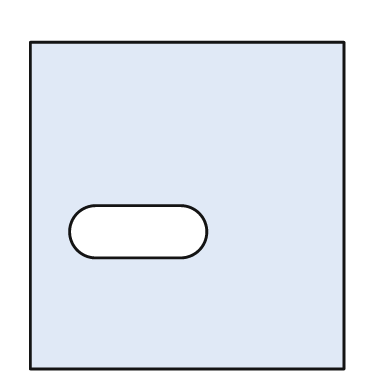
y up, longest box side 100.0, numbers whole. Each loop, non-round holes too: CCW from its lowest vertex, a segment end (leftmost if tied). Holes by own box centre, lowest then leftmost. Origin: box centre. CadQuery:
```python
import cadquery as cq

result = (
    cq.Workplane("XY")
    .moveTo(-48.0, -50.0)
    .lineTo(48.0, -50.0)
    .lineTo(48.0, 50.0)
    .lineTo(-48.0, 50.0)
    .close()
    .moveTo(-28.0, -16.0)
    .lineTo(-2.0, -16.0)
    .threePointArc((6.0, -8.0), (-2.0, 0.0))
    .lineTo(-28.0, 0.0)
    .threePointArc((-36.0, -8.0), (-28.0, -16.0))
    .close()
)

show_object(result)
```